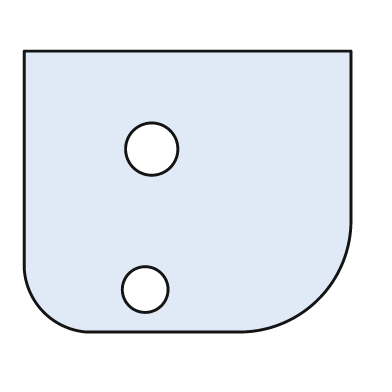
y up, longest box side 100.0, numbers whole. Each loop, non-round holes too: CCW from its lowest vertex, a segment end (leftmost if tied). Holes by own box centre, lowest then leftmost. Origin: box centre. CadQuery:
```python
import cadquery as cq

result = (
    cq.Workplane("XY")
    .moveTo(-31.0, -43.0)
    .lineTo(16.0, -43.0)
    .threePointArc((40.0, -33.0), (50.0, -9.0))
    .lineTo(50.0, 43.0)
    .lineTo(-50.0, 43.0)
    .lineTo(-50.0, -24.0)
    .threePointArc((-44.0, -37.0), (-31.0, -43.0))
    .close()
    .moveTo(-13.0, -30.0)
    .circle(7.0)
    .moveTo(-11.0, 13.0)
    .circle(8.0)
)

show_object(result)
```